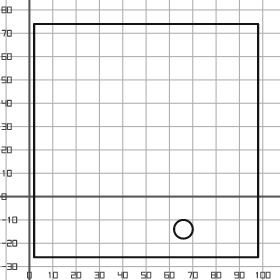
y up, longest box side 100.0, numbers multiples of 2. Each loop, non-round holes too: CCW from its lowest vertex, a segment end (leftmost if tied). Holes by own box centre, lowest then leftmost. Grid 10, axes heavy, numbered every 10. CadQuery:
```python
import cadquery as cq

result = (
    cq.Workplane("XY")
    .moveTo(2.0, -26.0)
    .lineTo(98.0, -26.0)
    .lineTo(98.0, 74.0)
    .lineTo(2.0, 74.0)
    .close()
    .moveTo(66.0, -14.0)
    .circle(4.0)
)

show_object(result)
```